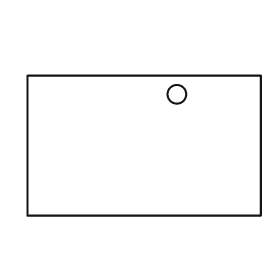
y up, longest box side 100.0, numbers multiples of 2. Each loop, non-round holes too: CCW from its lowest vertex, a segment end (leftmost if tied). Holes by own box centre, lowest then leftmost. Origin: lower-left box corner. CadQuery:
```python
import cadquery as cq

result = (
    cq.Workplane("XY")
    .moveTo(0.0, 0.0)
    .lineTo(100.0, 0.0)
    .lineTo(100.0, 60.0)
    .lineTo(0.0, 60.0)
    .close()
    .moveTo(64.0, 52.0)
    .circle(4.0)
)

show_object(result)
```